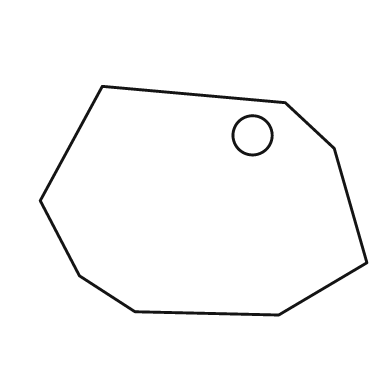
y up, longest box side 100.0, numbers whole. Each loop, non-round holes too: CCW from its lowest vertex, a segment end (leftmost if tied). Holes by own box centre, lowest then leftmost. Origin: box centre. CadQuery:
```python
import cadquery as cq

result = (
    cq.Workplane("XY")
    .moveTo(23.0, -35.0)
    .lineTo(50.0, -19.0)
    .lineTo(40.0, 16.0)
    .lineTo(25.0, 30.0)
    .lineTo(-31.0, 35.0)
    .lineTo(-50.0, 0.0)
    .lineTo(-38.0, -23.0)
    .lineTo(-21.0, -34.0)
    .close()
    .moveTo(15.0, 20.0)
    .circle(6.0)
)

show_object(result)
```